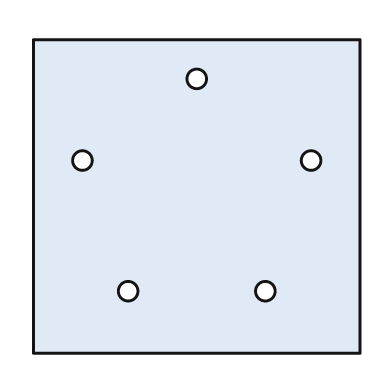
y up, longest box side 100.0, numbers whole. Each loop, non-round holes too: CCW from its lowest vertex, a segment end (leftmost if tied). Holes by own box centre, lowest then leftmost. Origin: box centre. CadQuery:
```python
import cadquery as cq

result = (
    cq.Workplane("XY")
    .moveTo(-50.0, -48.0)
    .lineTo(50.0, -48.0)
    .lineTo(50.0, 48.0)
    .lineTo(-50.0, 48.0)
    .close()
    .moveTo(-21.0, -29.0)
    .circle(3.0)
    .moveTo(21.0, -29.0)
    .circle(3.0)
    .moveTo(-35.0, 11.0)
    .circle(3.0)
    .moveTo(35.0, 11.0)
    .circle(3.0)
    .moveTo(0.0, 36.0)
    .circle(3.0)
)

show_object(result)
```